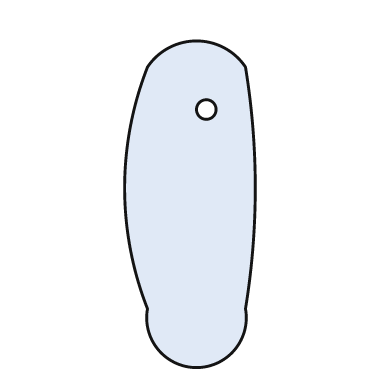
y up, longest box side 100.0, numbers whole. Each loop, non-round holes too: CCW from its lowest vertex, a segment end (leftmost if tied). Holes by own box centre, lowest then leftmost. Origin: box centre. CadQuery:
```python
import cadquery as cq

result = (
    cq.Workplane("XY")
    .moveTo(-13.0, -32.0)
    .threePointArc((2.0, -50.0), (17.0, -32.0))
    .threePointArc((20.0, 5.0), (17.0, 42.0))
    .threePointArc((2.0, 50.0), (-13.0, 42.0))
    .threePointArc((-20.0, 5.0), (-13.0, -32.0))
    .close()
    .moveTo(5.0, 29.0)
    .circle(3.0)
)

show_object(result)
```